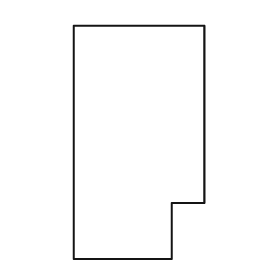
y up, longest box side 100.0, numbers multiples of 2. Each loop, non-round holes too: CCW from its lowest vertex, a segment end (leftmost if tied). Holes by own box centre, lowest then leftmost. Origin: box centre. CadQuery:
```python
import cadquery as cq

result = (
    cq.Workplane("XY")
    .moveTo(-28.0, -50.0)
    .lineTo(14.0, -50.0)
    .lineTo(14.0, -26.0)
    .lineTo(28.0, -26.0)
    .lineTo(28.0, 50.0)
    .lineTo(-28.0, 50.0)
    .close()
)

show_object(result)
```